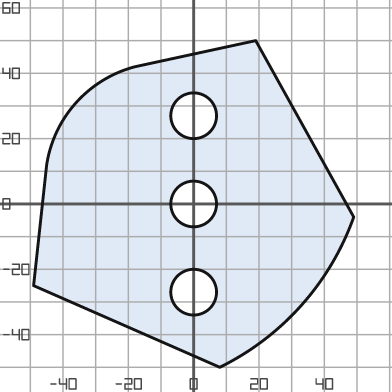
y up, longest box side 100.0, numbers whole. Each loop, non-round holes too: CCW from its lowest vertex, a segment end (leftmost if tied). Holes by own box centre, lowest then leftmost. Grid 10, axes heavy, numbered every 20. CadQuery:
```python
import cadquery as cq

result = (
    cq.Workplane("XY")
    .moveTo(8.0, -50.0)
    .threePointArc((33.0, -31.0), (49.0, -4.0))
    .lineTo(19.0, 50.0)
    .lineTo(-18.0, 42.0)
    .threePointArc((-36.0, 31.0), (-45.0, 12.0))
    .lineTo(-49.0, -25.0)
    .close()
    .moveTo(0.0, -27.0)
    .circle(7.0)
    .moveTo(0.0, 0.0)
    .circle(7.0)
    .moveTo(0.0, 27.0)
    .circle(7.0)
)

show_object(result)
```